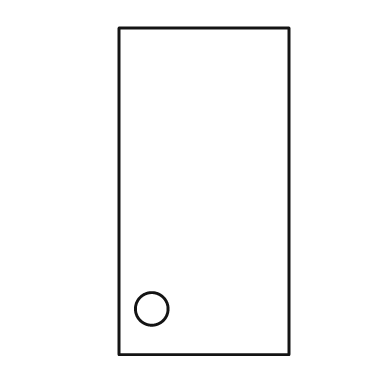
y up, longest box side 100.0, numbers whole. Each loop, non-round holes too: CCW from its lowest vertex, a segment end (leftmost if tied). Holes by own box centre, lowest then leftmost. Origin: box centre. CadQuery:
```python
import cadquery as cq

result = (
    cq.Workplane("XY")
    .moveTo(-26.0, -50.0)
    .lineTo(26.0, -50.0)
    .lineTo(26.0, 50.0)
    .lineTo(-26.0, 50.0)
    .close()
    .moveTo(-16.0, -36.0)
    .circle(5.0)
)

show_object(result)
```